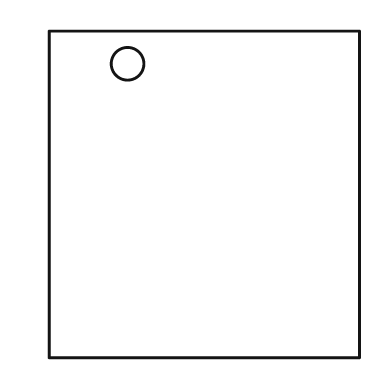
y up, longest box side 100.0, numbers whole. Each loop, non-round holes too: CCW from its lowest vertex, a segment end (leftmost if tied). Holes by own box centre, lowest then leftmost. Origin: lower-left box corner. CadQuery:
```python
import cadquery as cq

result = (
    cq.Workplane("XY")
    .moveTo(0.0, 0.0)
    .lineTo(95.0, 0.0)
    .lineTo(95.0, 100.0)
    .lineTo(0.0, 100.0)
    .close()
    .moveTo(24.0, 90.0)
    .circle(5.0)
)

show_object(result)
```